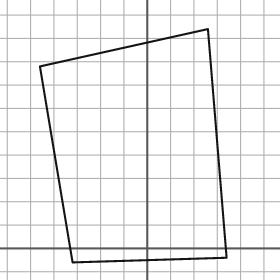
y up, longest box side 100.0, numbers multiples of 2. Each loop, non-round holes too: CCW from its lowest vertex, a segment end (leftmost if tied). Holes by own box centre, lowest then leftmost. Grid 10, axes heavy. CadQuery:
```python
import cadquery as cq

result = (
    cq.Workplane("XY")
    .moveTo(-32.0, -6.0)
    .lineTo(34.0, -4.0)
    .lineTo(26.0, 94.0)
    .lineTo(-46.0, 78.0)
    .close()
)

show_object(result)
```